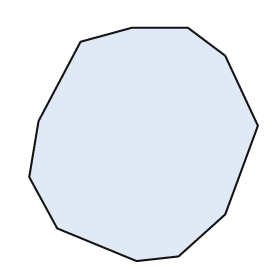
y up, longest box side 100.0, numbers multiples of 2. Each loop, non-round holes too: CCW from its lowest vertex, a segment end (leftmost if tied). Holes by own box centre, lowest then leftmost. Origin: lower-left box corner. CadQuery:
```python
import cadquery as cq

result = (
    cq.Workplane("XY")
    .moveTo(46.0, 0.0)
    .lineTo(64.0, 2.0)
    .lineTo(84.0, 20.0)
    .lineTo(98.0, 58.0)
    .lineTo(84.0, 88.0)
    .lineTo(68.0, 100.0)
    .lineTo(44.0, 100.0)
    .lineTo(22.0, 94.0)
    .lineTo(4.0, 60.0)
    .lineTo(0.0, 36.0)
    .lineTo(12.0, 14.0)
    .close()
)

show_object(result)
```